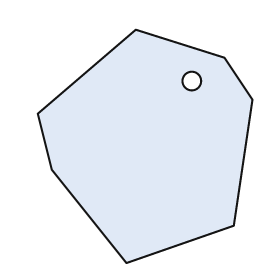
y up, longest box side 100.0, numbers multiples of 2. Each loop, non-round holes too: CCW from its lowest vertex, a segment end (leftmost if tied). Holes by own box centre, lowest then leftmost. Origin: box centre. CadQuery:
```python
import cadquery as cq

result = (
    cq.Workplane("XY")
    .moveTo(-8.0, -50.0)
    .lineTo(38.0, -34.0)
    .lineTo(46.0, 20.0)
    .lineTo(34.0, 38.0)
    .lineTo(-4.0, 50.0)
    .lineTo(-46.0, 14.0)
    .lineTo(-40.0, -10.0)
    .close()
    .moveTo(20.0, 28.0)
    .circle(4.0)
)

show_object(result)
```